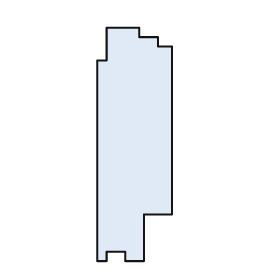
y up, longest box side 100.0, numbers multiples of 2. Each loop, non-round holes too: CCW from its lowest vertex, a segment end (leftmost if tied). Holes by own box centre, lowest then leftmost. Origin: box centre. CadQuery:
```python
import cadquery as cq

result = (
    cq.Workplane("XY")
    .moveTo(-16.0, -50.0)
    .lineTo(-12.0, -50.0)
    .lineTo(-12.0, -46.0)
    .lineTo(-4.0, -46.0)
    .lineTo(-4.0, -50.0)
    .lineTo(4.0, -50.0)
    .lineTo(4.0, -30.0)
    .lineTo(16.0, -30.0)
    .lineTo(16.0, 42.0)
    .lineTo(10.0, 42.0)
    .lineTo(10.0, 46.0)
    .lineTo(2.0, 46.0)
    .lineTo(2.0, 50.0)
    .lineTo(-12.0, 50.0)
    .lineTo(-12.0, 36.0)
    .lineTo(-16.0, 36.0)
    .close()
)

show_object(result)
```